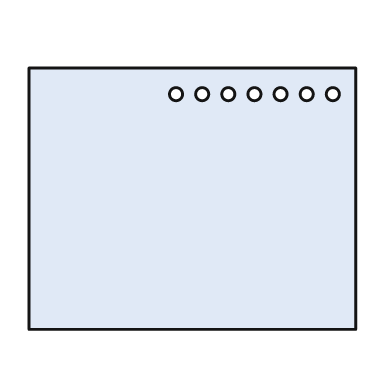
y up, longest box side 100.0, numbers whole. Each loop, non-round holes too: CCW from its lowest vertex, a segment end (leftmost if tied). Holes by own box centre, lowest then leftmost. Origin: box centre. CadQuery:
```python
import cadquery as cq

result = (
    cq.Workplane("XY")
    .moveTo(-50.0, -40.0)
    .lineTo(50.0, -40.0)
    .lineTo(50.0, 40.0)
    .lineTo(-50.0, 40.0)
    .close()
    .moveTo(-5.0, 32.0)
    .circle(2.0)
    .moveTo(3.0, 32.0)
    .circle(2.0)
    .moveTo(11.0, 32.0)
    .circle(2.0)
    .moveTo(19.0, 32.0)
    .circle(2.0)
    .moveTo(27.0, 32.0)
    .circle(2.0)
    .moveTo(35.0, 32.0)
    .circle(2.0)
    .moveTo(43.0, 32.0)
    .circle(2.0)
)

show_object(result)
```